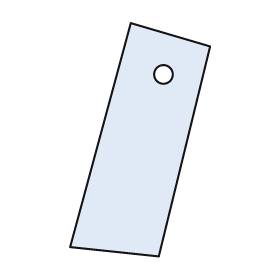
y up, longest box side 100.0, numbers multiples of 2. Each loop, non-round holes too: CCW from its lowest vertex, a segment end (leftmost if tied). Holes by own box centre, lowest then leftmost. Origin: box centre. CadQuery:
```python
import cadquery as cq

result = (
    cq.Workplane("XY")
    .moveTo(8.0, -50.0)
    .lineTo(30.0, 40.0)
    .lineTo(-4.0, 50.0)
    .lineTo(-30.0, -46.0)
    .close()
    .moveTo(10.0, 28.0)
    .circle(4.0)
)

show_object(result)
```